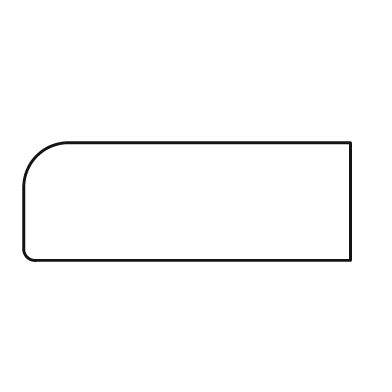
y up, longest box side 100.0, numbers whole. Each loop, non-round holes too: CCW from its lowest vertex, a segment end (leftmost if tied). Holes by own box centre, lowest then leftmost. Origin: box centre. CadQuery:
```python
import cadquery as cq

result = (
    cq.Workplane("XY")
    .moveTo(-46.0, -18.0)
    .lineTo(50.0, -18.0)
    .lineTo(50.0, 18.0)
    .lineTo(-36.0, 18.0)
    .threePointArc((-46.0, 14.0), (-50.0, 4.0))
    .lineTo(-50.0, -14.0)
    .threePointArc((-49.0, -17.0), (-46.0, -18.0))
    .close()
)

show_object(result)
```